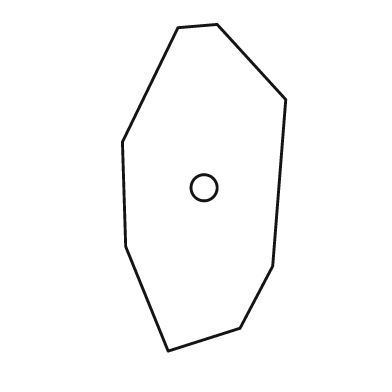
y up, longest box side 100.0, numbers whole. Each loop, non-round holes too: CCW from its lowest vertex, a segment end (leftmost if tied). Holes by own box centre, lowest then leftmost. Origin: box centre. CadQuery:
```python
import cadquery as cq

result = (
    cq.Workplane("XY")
    .moveTo(-11.0, -50.0)
    .lineTo(11.0, -43.0)
    .lineTo(21.0, -24.0)
    .lineTo(25.0, 27.0)
    .lineTo(4.0, 50.0)
    .lineTo(-8.0, 49.0)
    .lineTo(-25.0, 14.0)
    .lineTo(-24.0, -18.0)
    .close()
    .moveTo(0.0, 0.0)
    .circle(4.0)
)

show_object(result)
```